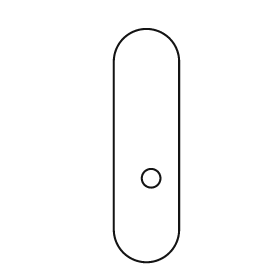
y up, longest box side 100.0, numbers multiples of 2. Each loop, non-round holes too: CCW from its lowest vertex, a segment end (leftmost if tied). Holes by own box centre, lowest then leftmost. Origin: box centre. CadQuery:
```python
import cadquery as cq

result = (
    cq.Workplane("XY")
    .moveTo(-14.0, -36.0)
    .threePointArc((0.0, -50.0), (14.0, -36.0))
    .lineTo(14.0, 36.0)
    .threePointArc((0.0, 50.0), (-14.0, 36.0))
    .close()
    .moveTo(2.0, -14.0)
    .circle(4.0)
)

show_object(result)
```